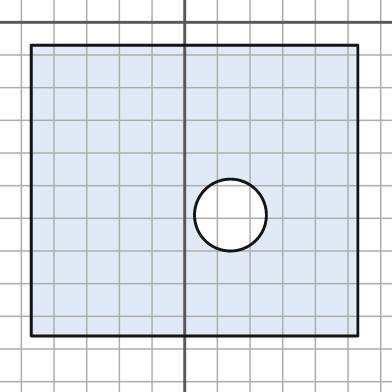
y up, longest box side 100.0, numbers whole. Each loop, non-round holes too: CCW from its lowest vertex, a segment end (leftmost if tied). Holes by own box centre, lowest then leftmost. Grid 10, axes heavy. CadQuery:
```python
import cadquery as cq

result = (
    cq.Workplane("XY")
    .moveTo(-47.0, -96.0)
    .lineTo(53.0, -96.0)
    .lineTo(53.0, -7.0)
    .lineTo(-47.0, -7.0)
    .close()
    .moveTo(14.0, -59.0)
    .circle(11.0)
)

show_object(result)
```